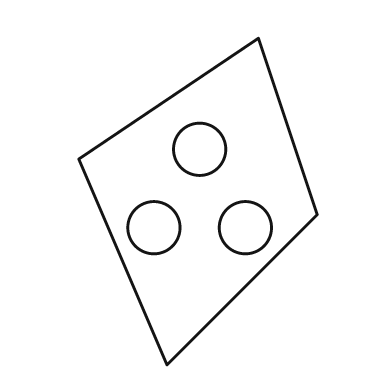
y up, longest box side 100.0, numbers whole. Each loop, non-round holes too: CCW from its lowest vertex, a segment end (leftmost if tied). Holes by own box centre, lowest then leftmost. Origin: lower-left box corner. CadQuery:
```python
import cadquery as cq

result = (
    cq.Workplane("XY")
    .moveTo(27.0, 0.0)
    .lineTo(73.0, 46.0)
    .lineTo(55.0, 100.0)
    .lineTo(0.0, 63.0)
    .close()
    .moveTo(23.0, 42.0)
    .circle(8.0)
    .moveTo(51.0, 42.0)
    .circle(8.0)
    .moveTo(37.0, 66.0)
    .circle(8.0)
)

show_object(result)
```